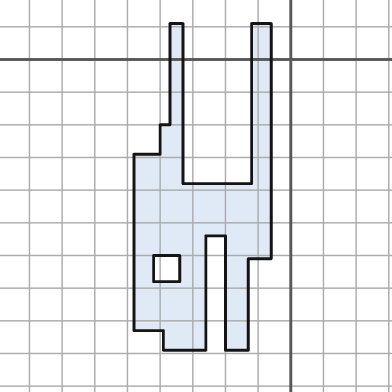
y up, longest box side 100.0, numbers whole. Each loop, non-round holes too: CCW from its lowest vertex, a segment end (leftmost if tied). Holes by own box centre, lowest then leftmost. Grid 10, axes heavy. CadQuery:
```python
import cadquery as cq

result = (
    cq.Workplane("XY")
    .moveTo(-39.0, -89.0)
    .lineTo(-26.0, -89.0)
    .lineTo(-26.0, -54.0)
    .lineTo(-20.0, -54.0)
    .lineTo(-20.0, -89.0)
    .lineTo(-13.0, -89.0)
    .lineTo(-13.0, -61.0)
    .lineTo(-6.0, -61.0)
    .lineTo(-6.0, 11.0)
    .lineTo(-12.0, 11.0)
    .lineTo(-12.0, -38.0)
    .lineTo(-33.0, -38.0)
    .lineTo(-33.0, 11.0)
    .lineTo(-37.0, 11.0)
    .lineTo(-37.0, -20.0)
    .lineTo(-40.0, -20.0)
    .lineTo(-40.0, -29.0)
    .lineTo(-48.0, -29.0)
    .lineTo(-48.0, -83.0)
    .lineTo(-39.0, -83.0)
    .close()
    .moveTo(-42.0, -68.0)
    .lineTo(-34.0, -68.0)
    .lineTo(-34.0, -60.0)
    .lineTo(-42.0, -60.0)
    .close()
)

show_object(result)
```